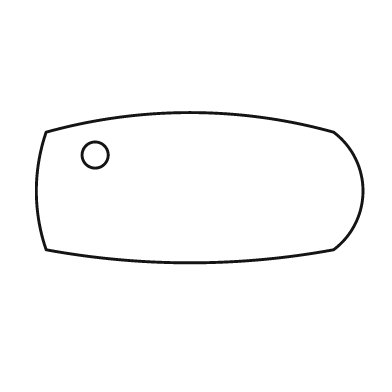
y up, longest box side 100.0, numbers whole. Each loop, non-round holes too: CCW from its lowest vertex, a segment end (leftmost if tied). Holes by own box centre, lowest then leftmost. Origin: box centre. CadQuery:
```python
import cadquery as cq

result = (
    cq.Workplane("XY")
    .moveTo(-47.0, -19.0)
    .threePointArc((-3.0, -23.0), (41.0, -19.0))
    .threePointArc((50.0, -1.0), (41.0, 17.0))
    .threePointArc((-3.0, 23.0), (-47.0, 17.0))
    .threePointArc((-50.0, -1.0), (-47.0, -19.0))
    .close()
    .moveTo(-32.0, 10.0)
    .circle(4.0)
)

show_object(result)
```